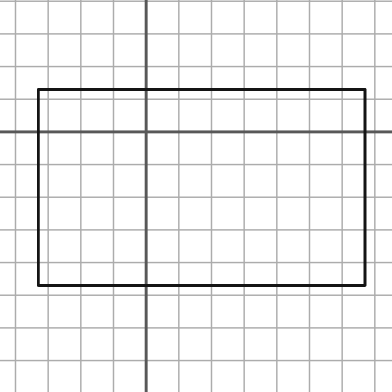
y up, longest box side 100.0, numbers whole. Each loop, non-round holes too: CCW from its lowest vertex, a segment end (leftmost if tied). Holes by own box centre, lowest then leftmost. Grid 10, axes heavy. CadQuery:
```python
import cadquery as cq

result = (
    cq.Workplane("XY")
    .moveTo(-33.0, -47.0)
    .lineTo(67.0, -47.0)
    .lineTo(67.0, 13.0)
    .lineTo(-33.0, 13.0)
    .close()
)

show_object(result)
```